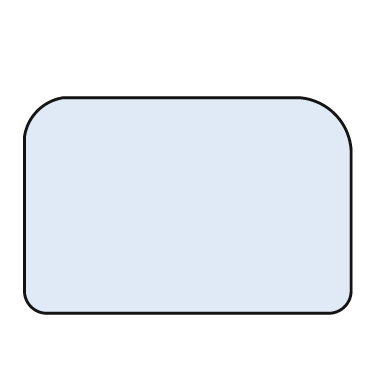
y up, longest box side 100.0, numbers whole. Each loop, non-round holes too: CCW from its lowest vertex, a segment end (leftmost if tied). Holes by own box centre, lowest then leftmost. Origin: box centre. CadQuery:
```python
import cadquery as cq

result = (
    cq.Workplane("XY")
    .moveTo(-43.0, -33.0)
    .lineTo(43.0, -33.0)
    .threePointArc((48.0, -31.0), (50.0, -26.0))
    .lineTo(50.0, 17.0)
    .threePointArc((45.0, 28.0), (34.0, 33.0))
    .lineTo(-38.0, 33.0)
    .threePointArc((-46.0, 29.0), (-50.0, 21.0))
    .lineTo(-50.0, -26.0)
    .threePointArc((-48.0, -31.0), (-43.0, -33.0))
    .close()
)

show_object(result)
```